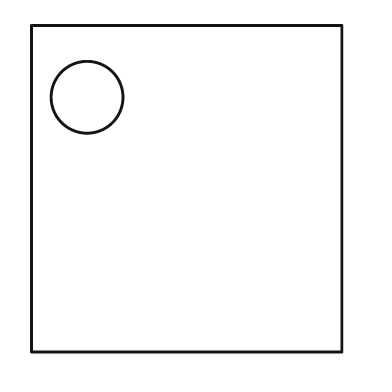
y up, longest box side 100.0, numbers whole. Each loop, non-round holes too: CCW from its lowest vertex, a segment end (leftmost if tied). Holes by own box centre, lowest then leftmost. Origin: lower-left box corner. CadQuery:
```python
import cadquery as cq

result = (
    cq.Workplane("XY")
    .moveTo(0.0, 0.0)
    .lineTo(95.0, 0.0)
    .lineTo(95.0, 100.0)
    .lineTo(0.0, 100.0)
    .close()
    .moveTo(17.0, 78.0)
    .circle(11.0)
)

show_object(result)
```